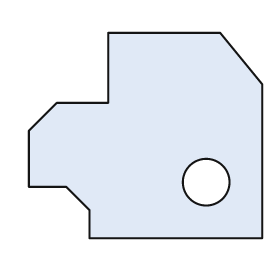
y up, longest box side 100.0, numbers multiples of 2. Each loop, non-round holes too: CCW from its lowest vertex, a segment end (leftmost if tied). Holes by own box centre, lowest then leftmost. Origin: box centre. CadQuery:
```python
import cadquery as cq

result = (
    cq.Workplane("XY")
    .moveTo(-24.0, -44.0)
    .lineTo(50.0, -44.0)
    .lineTo(50.0, 22.0)
    .lineTo(32.0, 44.0)
    .lineTo(-16.0, 44.0)
    .lineTo(-16.0, 14.0)
    .lineTo(-38.0, 14.0)
    .lineTo(-50.0, 2.0)
    .lineTo(-50.0, -22.0)
    .lineTo(-34.0, -22.0)
    .lineTo(-24.0, -32.0)
    .close()
    .moveTo(26.0, -20.0)
    .circle(10.0)
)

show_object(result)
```